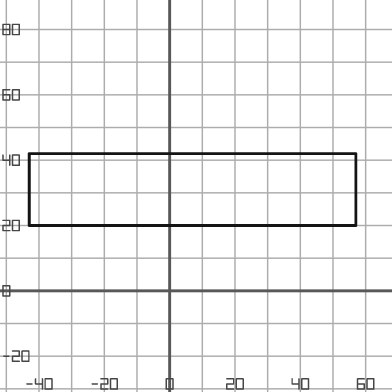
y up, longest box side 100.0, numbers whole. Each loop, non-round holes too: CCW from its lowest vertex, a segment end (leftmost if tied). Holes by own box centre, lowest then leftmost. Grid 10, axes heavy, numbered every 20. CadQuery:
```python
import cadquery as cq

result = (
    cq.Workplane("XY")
    .moveTo(-43.0, 20.0)
    .lineTo(57.0, 20.0)
    .lineTo(57.0, 42.0)
    .lineTo(-43.0, 42.0)
    .close()
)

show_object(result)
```